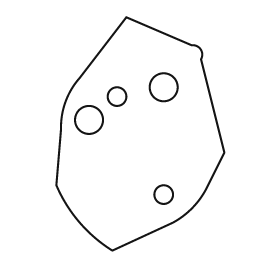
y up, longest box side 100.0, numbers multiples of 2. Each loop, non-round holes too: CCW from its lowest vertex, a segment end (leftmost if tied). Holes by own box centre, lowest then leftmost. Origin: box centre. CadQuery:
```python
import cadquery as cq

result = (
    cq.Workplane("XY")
    .moveTo(-12.0, -50.0)
    .lineTo(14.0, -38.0)
    .threePointArc((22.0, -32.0), (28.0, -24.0))
    .lineTo(36.0, -8.0)
    .lineTo(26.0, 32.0)
    .threePointArc((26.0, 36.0), (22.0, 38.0))
    .lineTo(-6.0, 50.0)
    .lineTo(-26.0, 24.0)
    .threePointArc((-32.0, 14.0), (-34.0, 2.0))
    .lineTo(-36.0, -22.0)
    .threePointArc((-26.0, -38.0), (-12.0, -50.0))
    .close()
    .moveTo(10.0, -26.0)
    .circle(4.0)
    .moveTo(-22.0, 6.0)
    .circle(6.0)
    .moveTo(-10.0, 16.0)
    .circle(4.0)
    .moveTo(10.0, 20.0)
    .circle(6.0)
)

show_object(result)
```